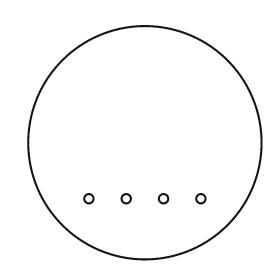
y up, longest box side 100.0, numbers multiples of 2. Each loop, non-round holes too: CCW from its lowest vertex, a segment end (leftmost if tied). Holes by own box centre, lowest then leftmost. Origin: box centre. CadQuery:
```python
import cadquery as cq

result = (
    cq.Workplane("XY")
    .moveTo(0.0, 0.0)
    .circle(50.0)
    .moveTo(-24.0, -24.0)
    .circle(2.0)
    .moveTo(-8.0, -24.0)
    .circle(2.0)
    .moveTo(8.0, -24.0)
    .circle(2.0)
    .moveTo(24.0, -24.0)
    .circle(2.0)
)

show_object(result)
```